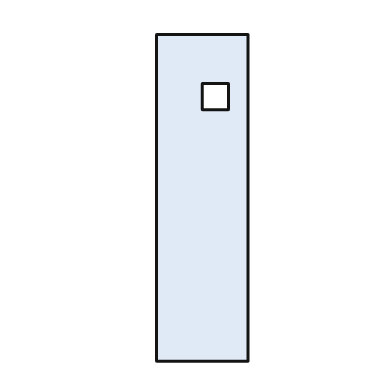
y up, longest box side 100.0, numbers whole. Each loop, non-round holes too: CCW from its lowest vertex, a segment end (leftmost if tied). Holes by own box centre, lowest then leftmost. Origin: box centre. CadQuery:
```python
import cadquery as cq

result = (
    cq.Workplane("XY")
    .moveTo(-14.0, -50.0)
    .lineTo(14.0, -50.0)
    .lineTo(14.0, 50.0)
    .lineTo(-14.0, 50.0)
    .close()
    .moveTo(0.0, 27.0)
    .lineTo(8.0, 27.0)
    .lineTo(8.0, 35.0)
    .lineTo(0.0, 35.0)
    .close()
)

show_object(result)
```